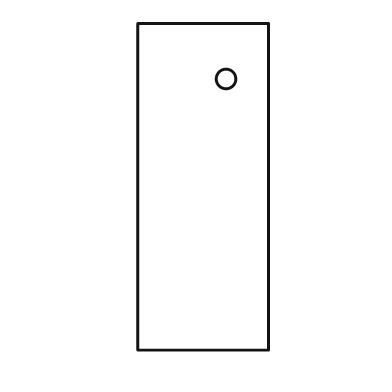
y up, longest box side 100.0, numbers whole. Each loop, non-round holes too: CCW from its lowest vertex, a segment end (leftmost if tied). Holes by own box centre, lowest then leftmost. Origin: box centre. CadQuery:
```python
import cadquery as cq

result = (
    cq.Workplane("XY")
    .moveTo(-20.0, -50.0)
    .lineTo(20.0, -50.0)
    .lineTo(20.0, 50.0)
    .lineTo(-20.0, 50.0)
    .close()
    .moveTo(7.0, 33.0)
    .circle(3.0)
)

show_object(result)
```